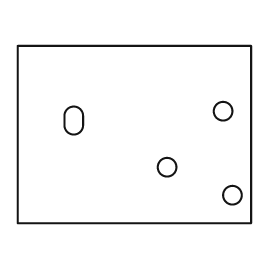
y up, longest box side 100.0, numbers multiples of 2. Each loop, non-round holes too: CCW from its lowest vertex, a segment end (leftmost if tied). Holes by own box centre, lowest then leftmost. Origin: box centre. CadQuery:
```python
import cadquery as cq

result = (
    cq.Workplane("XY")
    .moveTo(-50.0, -38.0)
    .lineTo(50.0, -38.0)
    .lineTo(50.0, 38.0)
    .lineTo(-50.0, 38.0)
    .close()
    .moveTo(42.0, -26.0)
    .circle(4.0)
    .moveTo(14.0, -14.0)
    .circle(4.0)
    .moveTo(-30.0, 4.0)
    .threePointArc((-26.0, 0.0), (-22.0, 4.0))
    .lineTo(-22.0, 8.0)
    .threePointArc((-26.0, 12.0), (-30.0, 8.0))
    .close()
    .moveTo(38.0, 10.0)
    .circle(4.0)
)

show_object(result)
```